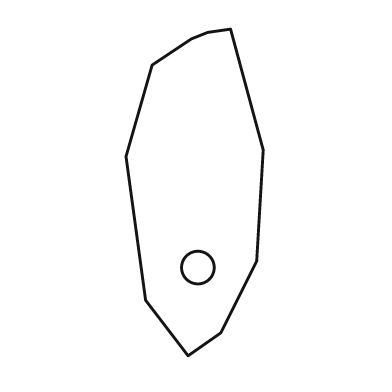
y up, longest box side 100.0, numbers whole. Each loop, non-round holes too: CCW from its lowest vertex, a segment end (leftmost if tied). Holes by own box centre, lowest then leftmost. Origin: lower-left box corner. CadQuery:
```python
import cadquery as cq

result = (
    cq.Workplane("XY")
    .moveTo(19.0, 0.0)
    .lineTo(29.0, 7.0)
    .lineTo(40.0, 29.0)
    .lineTo(42.0, 63.0)
    .lineTo(32.0, 100.0)
    .lineTo(25.0, 99.0)
    .lineTo(20.0, 97.0)
    .lineTo(8.0, 89.0)
    .lineTo(0.0, 61.0)
    .lineTo(6.0, 17.0)
    .close()
    .moveTo(22.0, 27.0)
    .circle(5.0)
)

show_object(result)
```